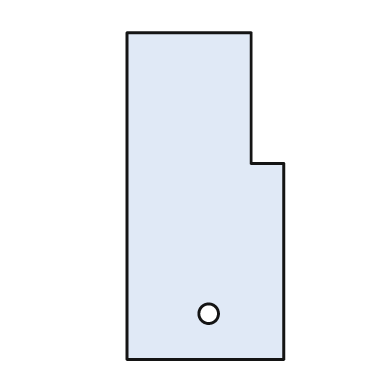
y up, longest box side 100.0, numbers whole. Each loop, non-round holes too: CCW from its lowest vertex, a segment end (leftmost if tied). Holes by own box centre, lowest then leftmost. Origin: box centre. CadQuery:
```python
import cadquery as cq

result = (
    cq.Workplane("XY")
    .moveTo(-24.0, -50.0)
    .lineTo(24.0, -50.0)
    .lineTo(24.0, 10.0)
    .lineTo(14.0, 10.0)
    .lineTo(14.0, 50.0)
    .lineTo(-24.0, 50.0)
    .close()
    .moveTo(1.0, -36.0)
    .circle(3.0)
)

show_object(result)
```